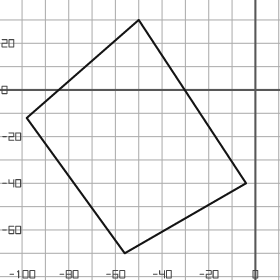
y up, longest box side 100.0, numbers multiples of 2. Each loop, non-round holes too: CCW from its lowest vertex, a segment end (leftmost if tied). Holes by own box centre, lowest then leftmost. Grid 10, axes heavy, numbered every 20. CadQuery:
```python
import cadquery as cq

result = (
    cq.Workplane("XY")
    .moveTo(-56.0, -70.0)
    .lineTo(-4.0, -40.0)
    .lineTo(-50.0, 30.0)
    .lineTo(-98.0, -12.0)
    .close()
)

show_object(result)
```